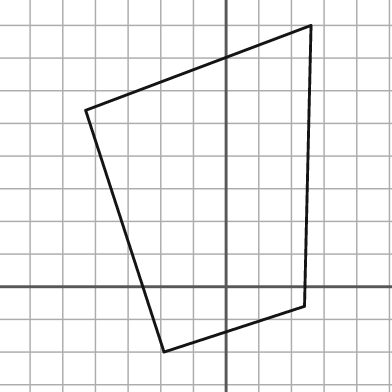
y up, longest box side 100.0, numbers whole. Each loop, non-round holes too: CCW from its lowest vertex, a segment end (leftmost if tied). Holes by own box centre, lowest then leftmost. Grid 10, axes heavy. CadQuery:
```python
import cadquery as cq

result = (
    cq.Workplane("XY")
    .moveTo(-19.0, -20.0)
    .lineTo(24.0, -6.0)
    .lineTo(26.0, 80.0)
    .lineTo(-43.0, 54.0)
    .close()
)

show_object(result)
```